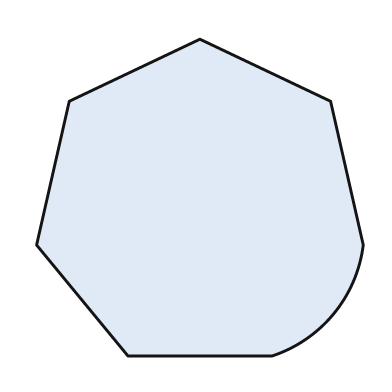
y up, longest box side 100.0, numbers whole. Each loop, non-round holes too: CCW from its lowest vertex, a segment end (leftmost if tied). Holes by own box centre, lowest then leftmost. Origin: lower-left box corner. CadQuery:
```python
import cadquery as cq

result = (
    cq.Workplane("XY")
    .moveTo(28.0, 0.0)
    .lineTo(72.0, 0.0)
    .threePointArc((91.0, 13.0), (100.0, 34.0))
    .lineTo(90.0, 78.0)
    .lineTo(50.0, 97.0)
    .lineTo(10.0, 78.0)
    .lineTo(0.0, 34.0)
    .close()
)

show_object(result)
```